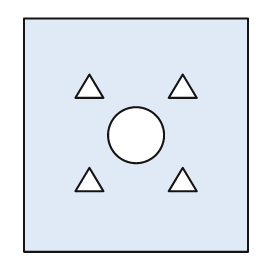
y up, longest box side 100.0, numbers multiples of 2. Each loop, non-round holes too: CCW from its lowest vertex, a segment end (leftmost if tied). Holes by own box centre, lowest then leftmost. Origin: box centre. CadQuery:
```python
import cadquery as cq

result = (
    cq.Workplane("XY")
    .moveTo(-48.0, -50.0)
    .lineTo(48.0, -50.0)
    .lineTo(48.0, 50.0)
    .lineTo(-48.0, 50.0)
    .close()
    .moveTo(-26.0, -24.0)
    .lineTo(-14.0, -24.0)
    .lineTo(-20.0, -14.0)
    .close()
    .moveTo(14.0, -24.0)
    .lineTo(26.0, -24.0)
    .lineTo(20.0, -14.0)
    .close()
    .moveTo(0.0, 0.0)
    .circle(12.0)
    .moveTo(-26.0, 16.0)
    .lineTo(-14.0, 16.0)
    .lineTo(-20.0, 26.0)
    .close()
    .moveTo(14.0, 16.0)
    .lineTo(26.0, 16.0)
    .lineTo(20.0, 26.0)
    .close()
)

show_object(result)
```